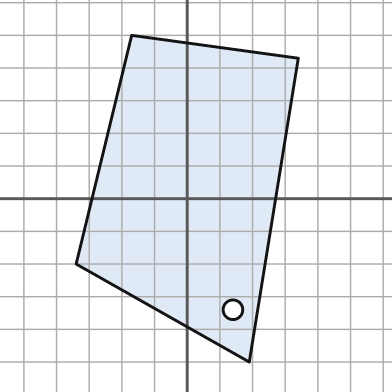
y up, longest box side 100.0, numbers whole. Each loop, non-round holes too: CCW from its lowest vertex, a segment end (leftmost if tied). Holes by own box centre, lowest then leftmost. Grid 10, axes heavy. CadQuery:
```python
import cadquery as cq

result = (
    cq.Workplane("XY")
    .moveTo(19.0, -50.0)
    .lineTo(34.0, 43.0)
    .lineTo(-17.0, 50.0)
    .lineTo(-34.0, -20.0)
    .close()
    .moveTo(14.0, -34.0)
    .circle(3.0)
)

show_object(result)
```